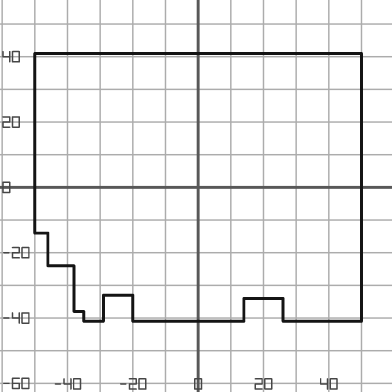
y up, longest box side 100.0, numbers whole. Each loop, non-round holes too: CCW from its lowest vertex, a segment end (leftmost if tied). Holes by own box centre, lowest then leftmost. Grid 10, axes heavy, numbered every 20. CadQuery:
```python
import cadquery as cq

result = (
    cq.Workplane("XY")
    .moveTo(-35.0, -41.0)
    .lineTo(-29.0, -41.0)
    .lineTo(-29.0, -33.0)
    .lineTo(-20.0, -33.0)
    .lineTo(-20.0, -41.0)
    .lineTo(14.0, -41.0)
    .lineTo(14.0, -34.0)
    .lineTo(26.0, -34.0)
    .lineTo(26.0, -41.0)
    .lineTo(50.0, -41.0)
    .lineTo(50.0, 41.0)
    .lineTo(-50.0, 41.0)
    .lineTo(-50.0, -14.0)
    .lineTo(-46.0, -14.0)
    .lineTo(-46.0, -24.0)
    .lineTo(-38.0, -24.0)
    .lineTo(-38.0, -38.0)
    .lineTo(-35.0, -38.0)
    .close()
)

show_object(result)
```